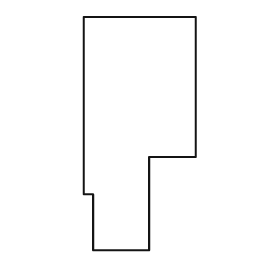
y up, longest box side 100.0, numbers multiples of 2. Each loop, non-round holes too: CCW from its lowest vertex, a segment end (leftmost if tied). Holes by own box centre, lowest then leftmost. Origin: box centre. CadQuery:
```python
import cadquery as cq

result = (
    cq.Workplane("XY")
    .moveTo(-20.0, -50.0)
    .lineTo(4.0, -50.0)
    .lineTo(4.0, -10.0)
    .lineTo(24.0, -10.0)
    .lineTo(24.0, 50.0)
    .lineTo(-24.0, 50.0)
    .lineTo(-24.0, -26.0)
    .lineTo(-20.0, -26.0)
    .close()
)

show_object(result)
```